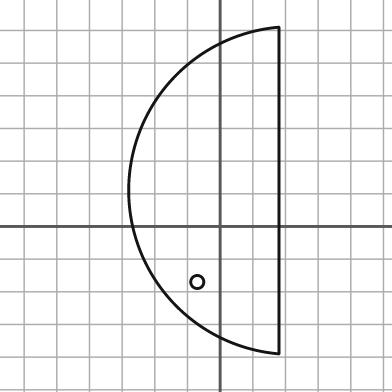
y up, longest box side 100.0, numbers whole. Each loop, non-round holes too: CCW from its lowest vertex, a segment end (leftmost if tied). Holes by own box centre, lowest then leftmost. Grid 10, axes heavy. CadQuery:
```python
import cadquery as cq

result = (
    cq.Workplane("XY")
    .moveTo(18.0, -39.0)
    .lineTo(18.0, 61.0)
    .threePointArc((-28.0, 11.0), (18.0, -39.0))
    .close()
    .moveTo(-7.0, -17.0)
    .circle(2.0)
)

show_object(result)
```